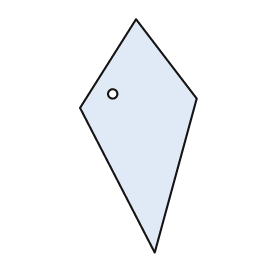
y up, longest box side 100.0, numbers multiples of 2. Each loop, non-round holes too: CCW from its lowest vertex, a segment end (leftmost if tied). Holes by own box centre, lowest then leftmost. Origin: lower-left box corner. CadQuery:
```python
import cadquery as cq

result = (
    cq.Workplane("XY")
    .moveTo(32.0, 0.0)
    .lineTo(50.0, 66.0)
    .lineTo(24.0, 100.0)
    .lineTo(0.0, 62.0)
    .close()
    .moveTo(14.0, 68.0)
    .circle(2.0)
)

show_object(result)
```